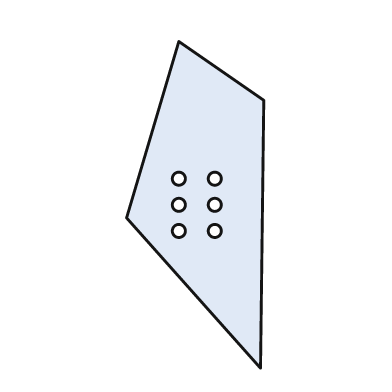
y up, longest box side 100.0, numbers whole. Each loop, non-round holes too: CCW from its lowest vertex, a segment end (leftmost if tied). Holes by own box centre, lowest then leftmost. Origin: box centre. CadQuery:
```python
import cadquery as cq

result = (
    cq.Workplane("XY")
    .moveTo(20.0, -50.0)
    .lineTo(21.0, 32.0)
    .lineTo(-5.0, 50.0)
    .lineTo(-21.0, -4.0)
    .close()
    .moveTo(-5.0, -8.0)
    .circle(2.0)
    .moveTo(6.0, -8.0)
    .circle(2.0)
    .moveTo(-5.0, 0.0)
    .circle(2.0)
    .moveTo(6.0, 0.0)
    .circle(2.0)
    .moveTo(-5.0, 8.0)
    .circle(2.0)
    .moveTo(6.0, 8.0)
    .circle(2.0)
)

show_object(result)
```